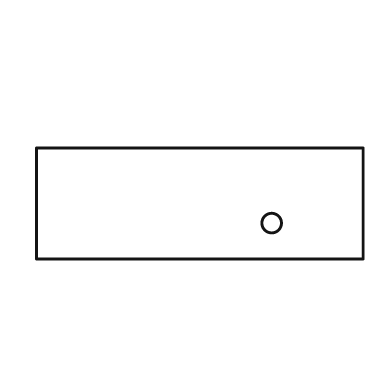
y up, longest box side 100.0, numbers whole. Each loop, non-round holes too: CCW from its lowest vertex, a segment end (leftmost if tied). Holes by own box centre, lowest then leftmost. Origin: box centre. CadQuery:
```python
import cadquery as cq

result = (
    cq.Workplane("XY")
    .moveTo(-50.0, -17.0)
    .lineTo(50.0, -17.0)
    .lineTo(50.0, 17.0)
    .lineTo(-50.0, 17.0)
    .close()
    .moveTo(22.0, -6.0)
    .circle(3.0)
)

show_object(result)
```